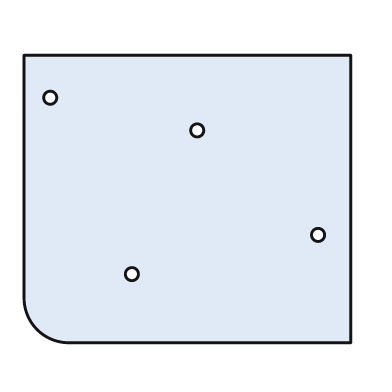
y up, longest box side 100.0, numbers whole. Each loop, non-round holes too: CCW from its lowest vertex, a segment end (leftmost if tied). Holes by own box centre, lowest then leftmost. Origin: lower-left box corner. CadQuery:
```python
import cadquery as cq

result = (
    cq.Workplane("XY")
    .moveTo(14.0, 0.0)
    .lineTo(100.0, 0.0)
    .lineTo(100.0, 88.0)
    .lineTo(0.0, 88.0)
    .lineTo(0.0, 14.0)
    .threePointArc((4.0, 4.0), (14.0, 0.0))
    .close()
    .moveTo(33.0, 21.0)
    .circle(2.0)
    .moveTo(90.0, 33.0)
    .circle(2.0)
    .moveTo(53.0, 65.0)
    .circle(2.0)
    .moveTo(8.0, 75.0)
    .circle(2.0)
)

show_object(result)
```